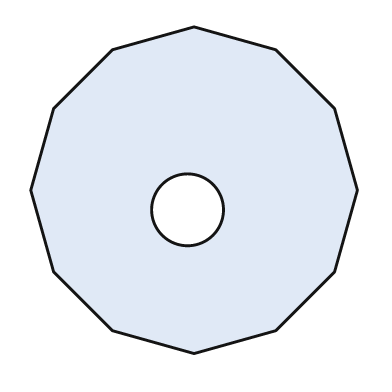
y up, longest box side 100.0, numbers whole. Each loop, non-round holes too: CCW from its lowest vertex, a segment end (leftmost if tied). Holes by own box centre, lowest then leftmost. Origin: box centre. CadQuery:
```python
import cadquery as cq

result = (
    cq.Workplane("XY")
    .moveTo(0.0, -50.0)
    .lineTo(25.0, -43.0)
    .lineTo(43.0, -25.0)
    .lineTo(50.0, 0.0)
    .lineTo(43.0, 25.0)
    .lineTo(25.0, 43.0)
    .lineTo(0.0, 50.0)
    .lineTo(-25.0, 43.0)
    .lineTo(-43.0, 25.0)
    .lineTo(-50.0, 0.0)
    .lineTo(-43.0, -25.0)
    .lineTo(-25.0, -43.0)
    .close()
    .moveTo(-2.0, -6.0)
    .circle(11.0)
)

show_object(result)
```